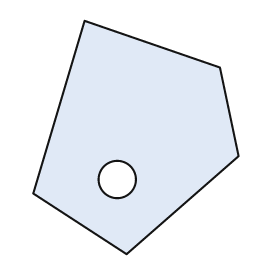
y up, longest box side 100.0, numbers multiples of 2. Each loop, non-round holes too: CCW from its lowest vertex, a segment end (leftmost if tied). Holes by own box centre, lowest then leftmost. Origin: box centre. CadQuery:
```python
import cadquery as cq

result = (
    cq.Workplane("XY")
    .moveTo(-4.0, -50.0)
    .lineTo(44.0, -8.0)
    .lineTo(36.0, 30.0)
    .lineTo(-22.0, 50.0)
    .lineTo(-44.0, -24.0)
    .close()
    .moveTo(-8.0, -18.0)
    .circle(8.0)
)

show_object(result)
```